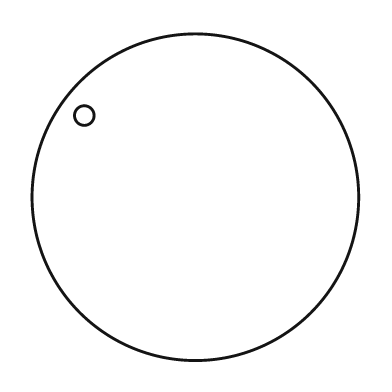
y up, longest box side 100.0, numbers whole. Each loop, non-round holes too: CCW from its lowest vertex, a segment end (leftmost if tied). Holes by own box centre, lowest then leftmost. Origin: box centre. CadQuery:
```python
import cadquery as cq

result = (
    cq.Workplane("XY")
    .moveTo(0.0, 0.0)
    .circle(50.0)
    .moveTo(-34.0, 25.0)
    .circle(3.0)
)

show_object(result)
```